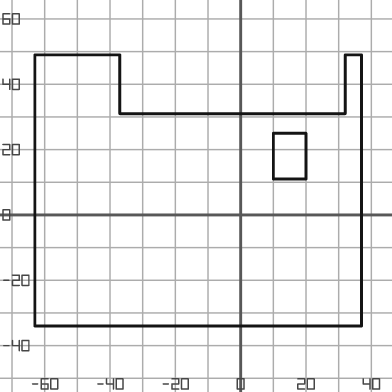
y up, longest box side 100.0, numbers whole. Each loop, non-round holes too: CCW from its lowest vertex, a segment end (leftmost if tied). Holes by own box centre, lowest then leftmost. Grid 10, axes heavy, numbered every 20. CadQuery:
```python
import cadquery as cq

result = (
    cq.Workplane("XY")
    .moveTo(-63.0, -34.0)
    .lineTo(37.0, -34.0)
    .lineTo(37.0, 49.0)
    .lineTo(32.0, 49.0)
    .lineTo(32.0, 31.0)
    .lineTo(-37.0, 31.0)
    .lineTo(-37.0, 49.0)
    .lineTo(-63.0, 49.0)
    .close()
    .moveTo(10.0, 11.0)
    .lineTo(20.0, 11.0)
    .lineTo(20.0, 25.0)
    .lineTo(10.0, 25.0)
    .close()
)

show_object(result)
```